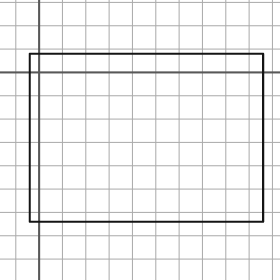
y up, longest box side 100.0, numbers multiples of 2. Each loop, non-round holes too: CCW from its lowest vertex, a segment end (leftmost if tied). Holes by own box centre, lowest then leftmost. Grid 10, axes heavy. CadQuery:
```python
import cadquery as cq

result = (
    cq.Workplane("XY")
    .moveTo(-4.0, -64.0)
    .lineTo(96.0, -64.0)
    .lineTo(96.0, 8.0)
    .lineTo(-4.0, 8.0)
    .close()
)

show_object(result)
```